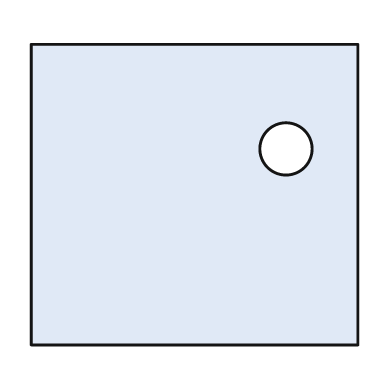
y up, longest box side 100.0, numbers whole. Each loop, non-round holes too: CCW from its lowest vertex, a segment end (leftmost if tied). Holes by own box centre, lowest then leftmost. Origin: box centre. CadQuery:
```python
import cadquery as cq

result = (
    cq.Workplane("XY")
    .moveTo(-50.0, -46.0)
    .lineTo(50.0, -46.0)
    .lineTo(50.0, 46.0)
    .lineTo(-50.0, 46.0)
    .close()
    .moveTo(28.0, 14.0)
    .circle(8.0)
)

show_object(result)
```